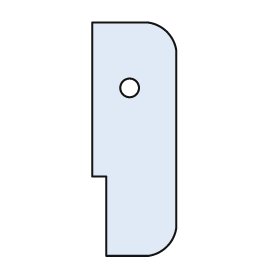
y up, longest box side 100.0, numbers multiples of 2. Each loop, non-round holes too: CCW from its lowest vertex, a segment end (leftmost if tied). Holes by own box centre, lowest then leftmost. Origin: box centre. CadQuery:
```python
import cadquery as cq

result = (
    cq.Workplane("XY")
    .moveTo(-12.0, -50.0)
    .lineTo(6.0, -50.0)
    .threePointArc((14.0, -46.0), (18.0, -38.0))
    .lineTo(18.0, 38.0)
    .threePointArc((14.0, 46.0), (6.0, 50.0))
    .lineTo(-18.0, 50.0)
    .lineTo(-18.0, -16.0)
    .lineTo(-12.0, -16.0)
    .close()
    .moveTo(-2.0, 22.0)
    .circle(4.0)
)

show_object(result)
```